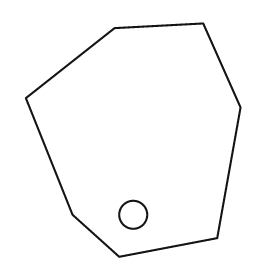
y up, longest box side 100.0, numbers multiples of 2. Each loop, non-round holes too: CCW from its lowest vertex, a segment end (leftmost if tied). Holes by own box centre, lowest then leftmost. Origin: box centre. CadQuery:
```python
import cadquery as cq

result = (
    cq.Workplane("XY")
    .moveTo(-6.0, -50.0)
    .lineTo(36.0, -42.0)
    .lineTo(46.0, 14.0)
    .lineTo(30.0, 50.0)
    .lineTo(-8.0, 48.0)
    .lineTo(-46.0, 18.0)
    .lineTo(-26.0, -32.0)
    .close()
    .moveTo(0.0, -32.0)
    .circle(6.0)
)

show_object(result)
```